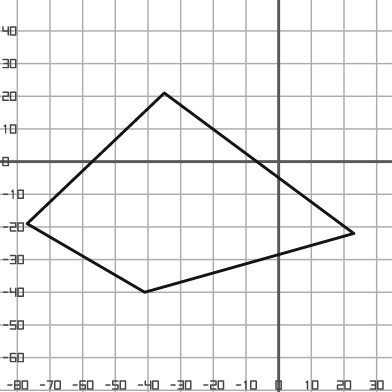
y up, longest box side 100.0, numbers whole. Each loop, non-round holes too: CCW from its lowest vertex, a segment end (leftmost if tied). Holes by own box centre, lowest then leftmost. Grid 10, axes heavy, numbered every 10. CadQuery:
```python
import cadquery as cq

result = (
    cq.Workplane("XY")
    .moveTo(-41.0, -40.0)
    .lineTo(23.0, -22.0)
    .lineTo(-35.0, 21.0)
    .lineTo(-77.0, -19.0)
    .close()
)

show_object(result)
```